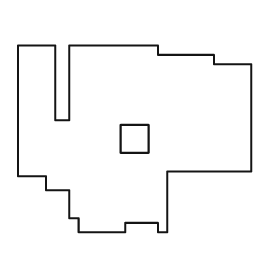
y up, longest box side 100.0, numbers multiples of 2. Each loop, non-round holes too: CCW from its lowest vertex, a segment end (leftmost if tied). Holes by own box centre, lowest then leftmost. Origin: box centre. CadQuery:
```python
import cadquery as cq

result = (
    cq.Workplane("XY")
    .moveTo(-24.0, -40.0)
    .lineTo(-4.0, -40.0)
    .lineTo(-4.0, -36.0)
    .lineTo(10.0, -36.0)
    .lineTo(10.0, -40.0)
    .lineTo(14.0, -40.0)
    .lineTo(14.0, -14.0)
    .lineTo(50.0, -14.0)
    .lineTo(50.0, 32.0)
    .lineTo(34.0, 32.0)
    .lineTo(34.0, 36.0)
    .lineTo(10.0, 36.0)
    .lineTo(10.0, 40.0)
    .lineTo(-28.0, 40.0)
    .lineTo(-28.0, 8.0)
    .lineTo(-34.0, 8.0)
    .lineTo(-34.0, 40.0)
    .lineTo(-50.0, 40.0)
    .lineTo(-50.0, -16.0)
    .lineTo(-38.0, -16.0)
    .lineTo(-38.0, -22.0)
    .lineTo(-28.0, -22.0)
    .lineTo(-28.0, -34.0)
    .lineTo(-24.0, -34.0)
    .close()
    .moveTo(-6.0, -6.0)
    .lineTo(6.0, -6.0)
    .lineTo(6.0, 6.0)
    .lineTo(-6.0, 6.0)
    .close()
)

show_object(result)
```